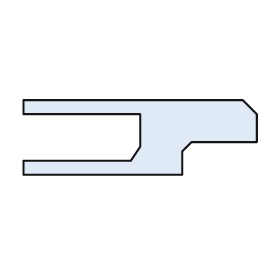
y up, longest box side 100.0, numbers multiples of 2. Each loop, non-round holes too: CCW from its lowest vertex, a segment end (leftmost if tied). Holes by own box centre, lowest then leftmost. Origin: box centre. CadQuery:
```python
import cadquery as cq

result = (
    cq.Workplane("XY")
    .moveTo(-50.0, -16.0)
    .lineTo(18.0, -16.0)
    .lineTo(18.0, -6.0)
    .lineTo(22.0, -2.0)
    .lineTo(50.0, -2.0)
    .lineTo(50.0, 10.0)
    .lineTo(44.0, 16.0)
    .lineTo(-50.0, 16.0)
    .lineTo(-50.0, 10.0)
    .lineTo(0.0, 10.0)
    .lineTo(0.0, -4.0)
    .lineTo(-4.0, -10.0)
    .lineTo(-50.0, -10.0)
    .close()
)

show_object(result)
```